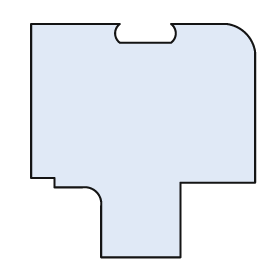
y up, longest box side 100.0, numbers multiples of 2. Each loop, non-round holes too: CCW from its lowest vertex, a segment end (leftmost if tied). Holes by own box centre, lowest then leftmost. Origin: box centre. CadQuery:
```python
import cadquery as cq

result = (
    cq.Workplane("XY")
    .moveTo(-18.0, -50.0)
    .lineTo(16.0, -50.0)
    .lineTo(16.0, -18.0)
    .lineTo(48.0, -18.0)
    .lineTo(48.0, 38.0)
    .threePointArc((44.0, 46.0), (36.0, 50.0))
    .lineTo(12.0, 50.0)
    .threePointArc((14.0, 46.0), (12.0, 42.0))
    .lineTo(-10.0, 42.0)
    .threePointArc((-12.0, 46.0), (-10.0, 50.0))
    .lineTo(-48.0, 50.0)
    .lineTo(-48.0, -16.0)
    .lineTo(-38.0, -16.0)
    .lineTo(-38.0, -20.0)
    .lineTo(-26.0, -20.0)
    .threePointArc((-20.0, -22.0), (-18.0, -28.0))
    .close()
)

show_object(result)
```